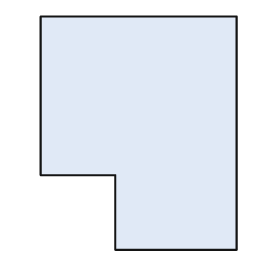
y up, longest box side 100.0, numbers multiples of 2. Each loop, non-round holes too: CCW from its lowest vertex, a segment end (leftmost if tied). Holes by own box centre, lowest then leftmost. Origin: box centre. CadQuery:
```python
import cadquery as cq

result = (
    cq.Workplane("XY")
    .moveTo(-10.0, -50.0)
    .lineTo(42.0, -50.0)
    .lineTo(42.0, 50.0)
    .lineTo(-42.0, 50.0)
    .lineTo(-42.0, -18.0)
    .lineTo(-10.0, -18.0)
    .close()
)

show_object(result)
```